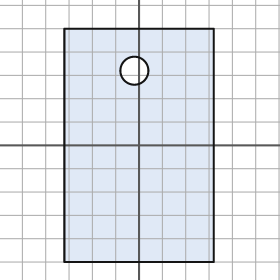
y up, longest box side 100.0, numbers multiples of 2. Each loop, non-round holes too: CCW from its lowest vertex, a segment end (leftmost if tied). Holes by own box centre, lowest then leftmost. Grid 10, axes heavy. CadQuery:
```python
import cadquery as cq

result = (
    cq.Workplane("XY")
    .moveTo(-32.0, -50.0)
    .lineTo(32.0, -50.0)
    .lineTo(32.0, 50.0)
    .lineTo(-32.0, 50.0)
    .close()
    .moveTo(-2.0, 32.0)
    .circle(6.0)
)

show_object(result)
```